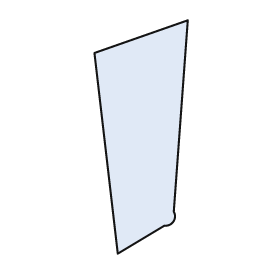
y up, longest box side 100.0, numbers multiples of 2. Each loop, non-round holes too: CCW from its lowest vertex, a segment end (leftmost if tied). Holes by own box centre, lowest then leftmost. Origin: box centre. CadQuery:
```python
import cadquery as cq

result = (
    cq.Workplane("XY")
    .moveTo(-10.0, -50.0)
    .lineTo(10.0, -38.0)
    .threePointArc((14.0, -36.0), (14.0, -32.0))
    .lineTo(20.0, 50.0)
    .lineTo(-20.0, 36.0)
    .close()
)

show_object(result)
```